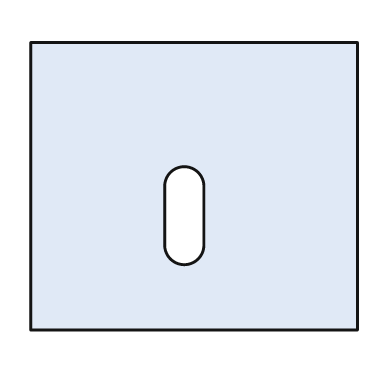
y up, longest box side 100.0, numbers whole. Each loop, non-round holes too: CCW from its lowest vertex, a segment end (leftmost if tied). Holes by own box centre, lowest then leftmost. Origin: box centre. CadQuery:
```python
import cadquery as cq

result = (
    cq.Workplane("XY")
    .moveTo(-50.0, -44.0)
    .lineTo(50.0, -44.0)
    .lineTo(50.0, 44.0)
    .lineTo(-50.0, 44.0)
    .close()
    .moveTo(-9.0, -18.0)
    .threePointArc((-3.0, -24.0), (3.0, -18.0))
    .lineTo(3.0, 0.0)
    .threePointArc((-3.0, 6.0), (-9.0, 0.0))
    .close()
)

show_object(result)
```